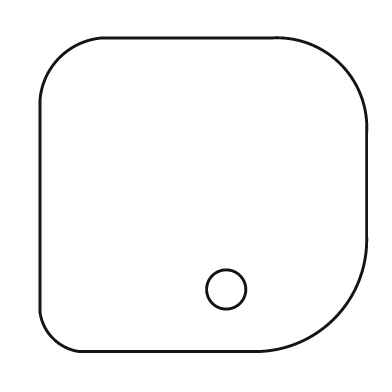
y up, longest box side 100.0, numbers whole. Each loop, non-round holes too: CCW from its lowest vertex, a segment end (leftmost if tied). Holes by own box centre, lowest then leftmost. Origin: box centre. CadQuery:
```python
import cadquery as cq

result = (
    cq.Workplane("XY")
    .moveTo(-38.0, -48.0)
    .lineTo(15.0, -48.0)
    .threePointArc((40.0, -38.0), (50.0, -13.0))
    .lineTo(50.0, 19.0)
    .threePointArc((42.0, 40.0), (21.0, 48.0))
    .lineTo(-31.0, 48.0)
    .threePointArc((-44.0, 42.0), (-50.0, 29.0))
    .lineTo(-50.0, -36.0)
    .threePointArc((-46.0, -44.0), (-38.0, -48.0))
    .close()
    .moveTo(7.0, -29.0)
    .circle(6.0)
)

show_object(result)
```